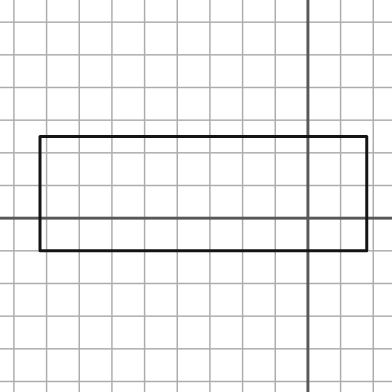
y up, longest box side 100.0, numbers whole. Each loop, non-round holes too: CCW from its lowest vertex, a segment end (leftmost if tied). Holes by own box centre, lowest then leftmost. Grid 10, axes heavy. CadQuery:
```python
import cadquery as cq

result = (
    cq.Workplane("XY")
    .moveTo(-82.0, -10.0)
    .lineTo(18.0, -10.0)
    .lineTo(18.0, 25.0)
    .lineTo(-82.0, 25.0)
    .close()
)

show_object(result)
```